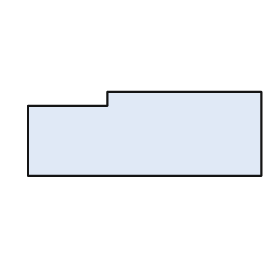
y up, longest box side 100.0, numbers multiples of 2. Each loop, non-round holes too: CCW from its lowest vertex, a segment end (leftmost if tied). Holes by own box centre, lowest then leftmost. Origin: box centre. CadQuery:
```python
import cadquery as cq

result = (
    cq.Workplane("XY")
    .moveTo(-50.0, -18.0)
    .lineTo(50.0, -18.0)
    .lineTo(50.0, 18.0)
    .lineTo(-16.0, 18.0)
    .lineTo(-16.0, 12.0)
    .lineTo(-50.0, 12.0)
    .close()
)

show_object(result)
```